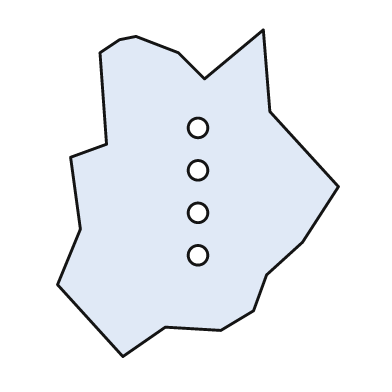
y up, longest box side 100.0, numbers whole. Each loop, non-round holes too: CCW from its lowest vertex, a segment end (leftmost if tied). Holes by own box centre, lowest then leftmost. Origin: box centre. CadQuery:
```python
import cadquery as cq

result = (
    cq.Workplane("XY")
    .moveTo(-23.0, -50.0)
    .lineTo(-10.0, -41.0)
    .lineTo(7.0, -42.0)
    .lineTo(17.0, -36.0)
    .lineTo(21.0, -25.0)
    .lineTo(32.0, -15.0)
    .lineTo(43.0, 2.0)
    .lineTo(22.0, 25.0)
    .lineTo(20.0, 50.0)
    .lineTo(2.0, 35.0)
    .lineTo(-6.0, 43.0)
    .lineTo(-19.0, 48.0)
    .lineTo(-24.0, 47.0)
    .lineTo(-30.0, 43.0)
    .lineTo(-28.0, 15.0)
    .lineTo(-39.0, 11.0)
    .lineTo(-36.0, -11.0)
    .lineTo(-43.0, -28.0)
    .close()
    .moveTo(0.0, -19.0)
    .circle(3.0)
    .moveTo(0.0, -6.0)
    .circle(3.0)
    .moveTo(0.0, 7.0)
    .circle(3.0)
    .moveTo(0.0, 20.0)
    .circle(3.0)
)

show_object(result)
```